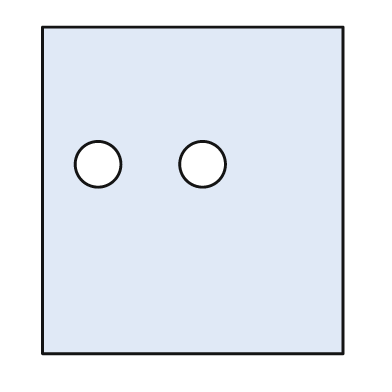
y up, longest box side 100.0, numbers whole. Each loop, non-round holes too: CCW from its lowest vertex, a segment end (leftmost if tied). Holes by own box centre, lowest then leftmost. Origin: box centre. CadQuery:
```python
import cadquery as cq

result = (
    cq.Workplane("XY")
    .moveTo(-46.0, -50.0)
    .lineTo(46.0, -50.0)
    .lineTo(46.0, 50.0)
    .lineTo(-46.0, 50.0)
    .close()
    .moveTo(-29.0, 8.0)
    .circle(7.0)
    .moveTo(3.0, 8.0)
    .circle(7.0)
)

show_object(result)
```